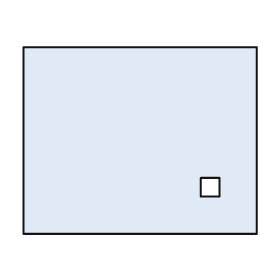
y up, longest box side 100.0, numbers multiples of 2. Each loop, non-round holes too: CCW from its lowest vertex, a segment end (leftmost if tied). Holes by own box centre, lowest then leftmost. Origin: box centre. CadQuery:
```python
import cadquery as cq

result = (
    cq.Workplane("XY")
    .moveTo(-50.0, -40.0)
    .lineTo(50.0, -40.0)
    .lineTo(50.0, 40.0)
    .lineTo(-50.0, 40.0)
    .close()
    .moveTo(26.0, -24.0)
    .lineTo(34.0, -24.0)
    .lineTo(34.0, -16.0)
    .lineTo(26.0, -16.0)
    .close()
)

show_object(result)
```